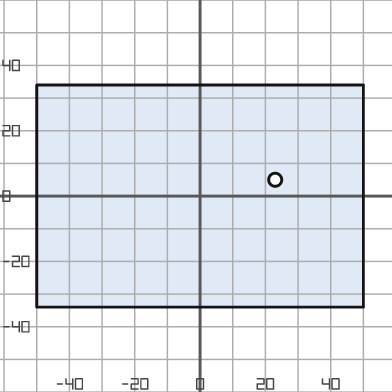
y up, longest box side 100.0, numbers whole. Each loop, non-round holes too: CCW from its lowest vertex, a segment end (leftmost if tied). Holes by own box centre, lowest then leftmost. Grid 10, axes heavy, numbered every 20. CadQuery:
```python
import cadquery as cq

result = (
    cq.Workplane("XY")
    .moveTo(-50.0, -34.0)
    .lineTo(50.0, -34.0)
    .lineTo(50.0, 34.0)
    .lineTo(-50.0, 34.0)
    .close()
    .moveTo(23.0, 5.0)
    .circle(2.0)
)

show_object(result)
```